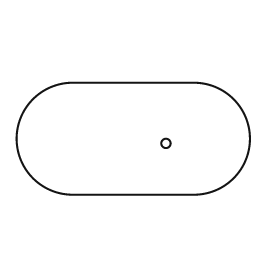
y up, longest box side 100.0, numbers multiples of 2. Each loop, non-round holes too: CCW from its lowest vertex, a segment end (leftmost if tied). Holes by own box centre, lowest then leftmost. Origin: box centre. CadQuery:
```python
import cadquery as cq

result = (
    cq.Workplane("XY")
    .moveTo(-26.0, -24.0)
    .lineTo(26.0, -24.0)
    .threePointArc((50.0, 0.0), (26.0, 24.0))
    .lineTo(-26.0, 24.0)
    .threePointArc((-50.0, 0.0), (-26.0, -24.0))
    .close()
    .moveTo(14.0, -2.0)
    .circle(2.0)
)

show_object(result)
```